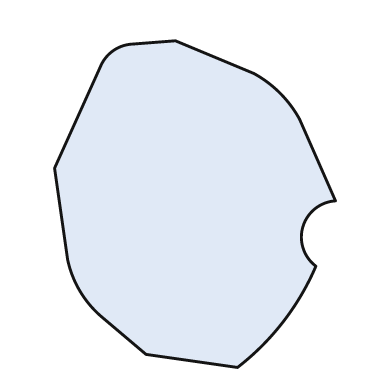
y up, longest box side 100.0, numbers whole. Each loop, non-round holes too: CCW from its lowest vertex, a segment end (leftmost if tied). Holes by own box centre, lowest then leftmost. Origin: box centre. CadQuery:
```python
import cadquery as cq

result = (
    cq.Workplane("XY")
    .moveTo(13.0, -50.0)
    .threePointArc((27.0, -36.0), (37.0, -19.0))
    .threePointArc((33.0, -7.0), (43.0, 1.0))
    .lineTo(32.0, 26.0)
    .threePointArc((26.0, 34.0), (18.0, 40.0))
    .lineTo(-6.0, 50.0)
    .lineTo(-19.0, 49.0)
    .threePointArc((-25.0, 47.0), (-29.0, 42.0))
    .lineTo(-43.0, 11.0)
    .lineTo(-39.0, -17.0)
    .threePointArc((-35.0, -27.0), (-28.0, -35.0))
    .lineTo(-15.0, -46.0)
    .close()
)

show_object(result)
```